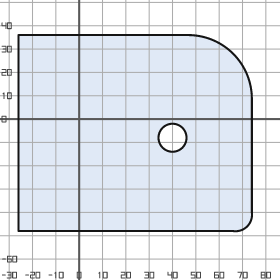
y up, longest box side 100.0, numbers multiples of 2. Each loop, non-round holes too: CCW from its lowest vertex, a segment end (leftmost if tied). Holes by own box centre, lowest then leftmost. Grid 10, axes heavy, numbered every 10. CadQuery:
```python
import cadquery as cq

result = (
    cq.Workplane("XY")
    .moveTo(-26.0, -48.0)
    .lineTo(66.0, -48.0)
    .threePointArc((72.0, -46.0), (74.0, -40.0))
    .lineTo(74.0, 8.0)
    .threePointArc((66.0, 28.0), (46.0, 36.0))
    .lineTo(-26.0, 36.0)
    .close()
    .moveTo(40.0, -8.0)
    .circle(6.0)
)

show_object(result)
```